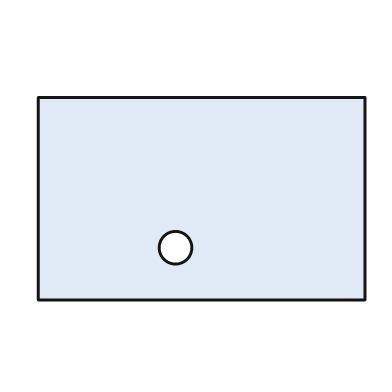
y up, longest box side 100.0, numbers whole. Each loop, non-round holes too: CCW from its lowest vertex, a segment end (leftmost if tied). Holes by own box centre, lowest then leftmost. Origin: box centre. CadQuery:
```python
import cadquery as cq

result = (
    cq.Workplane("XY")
    .moveTo(-50.0, -31.0)
    .lineTo(50.0, -31.0)
    .lineTo(50.0, 31.0)
    .lineTo(-50.0, 31.0)
    .close()
    .moveTo(-8.0, -15.0)
    .circle(5.0)
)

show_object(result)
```